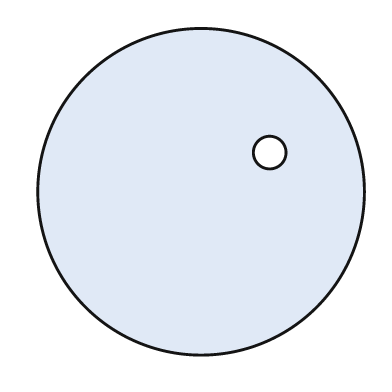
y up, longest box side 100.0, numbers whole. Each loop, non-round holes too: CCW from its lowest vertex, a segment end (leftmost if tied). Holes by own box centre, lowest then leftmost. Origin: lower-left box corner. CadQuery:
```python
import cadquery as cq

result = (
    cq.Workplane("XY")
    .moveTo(50.0, 50.0)
    .circle(50.0)
    .moveTo(71.0, 62.0)
    .circle(5.0)
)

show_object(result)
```